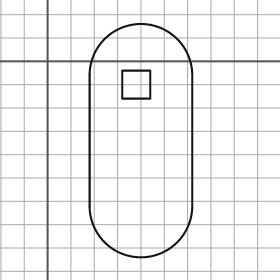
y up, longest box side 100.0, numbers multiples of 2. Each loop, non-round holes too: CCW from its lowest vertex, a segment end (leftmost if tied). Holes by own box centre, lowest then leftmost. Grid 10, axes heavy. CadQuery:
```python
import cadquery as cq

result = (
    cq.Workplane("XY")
    .moveTo(18.0, -62.0)
    .threePointArc((40.0, -84.0), (62.0, -62.0))
    .lineTo(62.0, -6.0)
    .threePointArc((40.0, 16.0), (18.0, -6.0))
    .close()
    .moveTo(32.0, -16.0)
    .lineTo(44.0, -16.0)
    .lineTo(44.0, -4.0)
    .lineTo(32.0, -4.0)
    .close()
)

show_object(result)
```